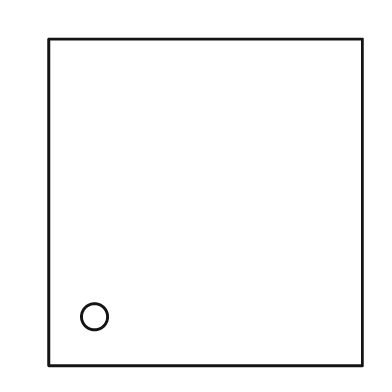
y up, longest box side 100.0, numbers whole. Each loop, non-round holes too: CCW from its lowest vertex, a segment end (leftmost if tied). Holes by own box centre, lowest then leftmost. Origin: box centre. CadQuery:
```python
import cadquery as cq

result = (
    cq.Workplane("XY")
    .moveTo(-48.0, -50.0)
    .lineTo(48.0, -50.0)
    .lineTo(48.0, 50.0)
    .lineTo(-48.0, 50.0)
    .close()
    .moveTo(-34.0, -35.0)
    .circle(4.0)
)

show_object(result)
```